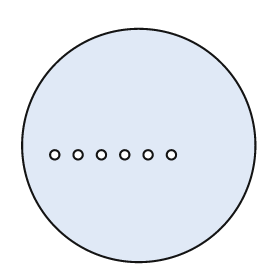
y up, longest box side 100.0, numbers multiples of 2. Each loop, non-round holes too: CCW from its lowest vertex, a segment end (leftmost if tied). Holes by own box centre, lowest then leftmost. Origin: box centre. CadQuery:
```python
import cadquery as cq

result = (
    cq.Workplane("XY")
    .moveTo(0.0, 0.0)
    .circle(50.0)
    .moveTo(-36.0, -4.0)
    .circle(2.0)
    .moveTo(-26.0, -4.0)
    .circle(2.0)
    .moveTo(-16.0, -4.0)
    .circle(2.0)
    .moveTo(-6.0, -4.0)
    .circle(2.0)
    .moveTo(4.0, -4.0)
    .circle(2.0)
    .moveTo(14.0, -4.0)
    .circle(2.0)
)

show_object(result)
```